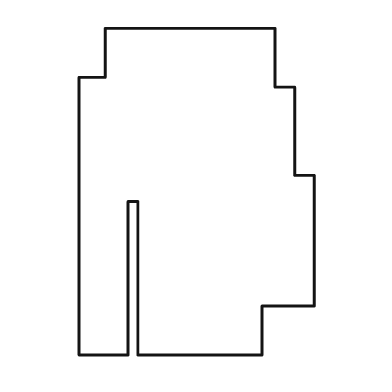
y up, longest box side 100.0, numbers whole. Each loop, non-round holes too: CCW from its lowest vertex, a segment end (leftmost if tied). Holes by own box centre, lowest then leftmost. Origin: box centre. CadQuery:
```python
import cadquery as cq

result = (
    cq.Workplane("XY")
    .moveTo(-36.0, -50.0)
    .lineTo(-21.0, -50.0)
    .lineTo(-21.0, -3.0)
    .lineTo(-18.0, -3.0)
    .lineTo(-18.0, -50.0)
    .lineTo(20.0, -50.0)
    .lineTo(20.0, -35.0)
    .lineTo(36.0, -35.0)
    .lineTo(36.0, 5.0)
    .lineTo(30.0, 5.0)
    .lineTo(30.0, 32.0)
    .lineTo(24.0, 32.0)
    .lineTo(24.0, 50.0)
    .lineTo(-28.0, 50.0)
    .lineTo(-28.0, 35.0)
    .lineTo(-36.0, 35.0)
    .close()
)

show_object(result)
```